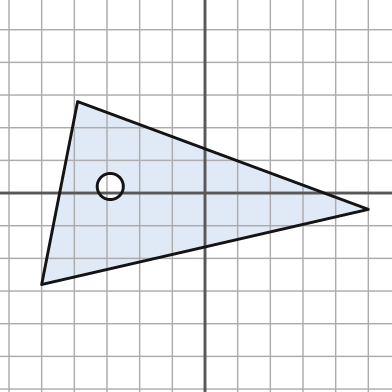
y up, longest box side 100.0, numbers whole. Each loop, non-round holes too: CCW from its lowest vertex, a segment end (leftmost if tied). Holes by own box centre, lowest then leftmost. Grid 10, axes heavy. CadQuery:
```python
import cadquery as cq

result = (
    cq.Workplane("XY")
    .moveTo(-50.0, -28.0)
    .lineTo(50.0, -5.0)
    .lineTo(-39.0, 28.0)
    .close()
    .moveTo(-29.0, 2.0)
    .circle(4.0)
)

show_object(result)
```